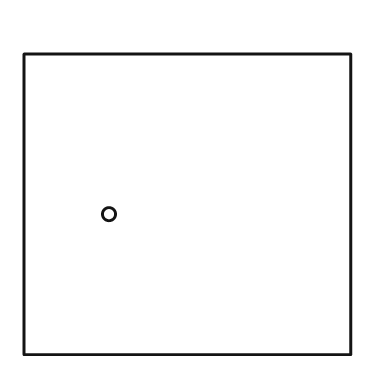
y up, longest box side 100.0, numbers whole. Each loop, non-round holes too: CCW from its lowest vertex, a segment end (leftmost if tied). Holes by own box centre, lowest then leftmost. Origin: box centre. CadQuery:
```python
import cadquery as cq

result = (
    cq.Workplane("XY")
    .moveTo(-50.0, -46.0)
    .lineTo(50.0, -46.0)
    .lineTo(50.0, 46.0)
    .lineTo(-50.0, 46.0)
    .close()
    .moveTo(-24.0, -3.0)
    .circle(2.0)
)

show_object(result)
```